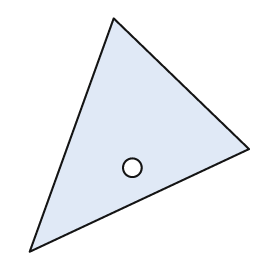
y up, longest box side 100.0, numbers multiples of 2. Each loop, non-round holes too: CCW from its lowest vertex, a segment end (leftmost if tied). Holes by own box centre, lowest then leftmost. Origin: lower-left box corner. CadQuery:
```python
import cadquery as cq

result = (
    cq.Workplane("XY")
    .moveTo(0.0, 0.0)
    .lineTo(94.0, 44.0)
    .lineTo(36.0, 100.0)
    .close()
    .moveTo(44.0, 36.0)
    .circle(4.0)
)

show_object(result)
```